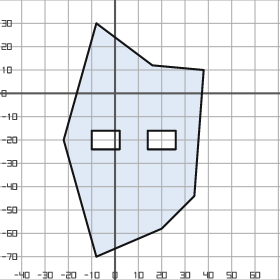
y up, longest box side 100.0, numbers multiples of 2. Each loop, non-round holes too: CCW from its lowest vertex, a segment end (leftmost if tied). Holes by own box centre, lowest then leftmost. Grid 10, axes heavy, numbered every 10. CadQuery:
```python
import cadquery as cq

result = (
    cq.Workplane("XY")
    .moveTo(-8.0, -70.0)
    .lineTo(20.0, -58.0)
    .lineTo(34.0, -44.0)
    .lineTo(38.0, 10.0)
    .lineTo(16.0, 12.0)
    .lineTo(-8.0, 30.0)
    .lineTo(-22.0, -20.0)
    .close()
    .moveTo(-10.0, -24.0)
    .lineTo(2.0, -24.0)
    .lineTo(2.0, -16.0)
    .lineTo(-10.0, -16.0)
    .close()
    .moveTo(14.0, -24.0)
    .lineTo(26.0, -24.0)
    .lineTo(26.0, -16.0)
    .lineTo(14.0, -16.0)
    .close()
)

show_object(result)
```